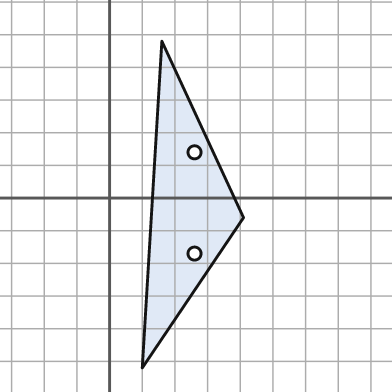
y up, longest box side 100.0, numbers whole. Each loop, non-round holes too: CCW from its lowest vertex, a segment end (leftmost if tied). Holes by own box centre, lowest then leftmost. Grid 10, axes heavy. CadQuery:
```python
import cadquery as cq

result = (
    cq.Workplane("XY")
    .moveTo(10.0, -52.0)
    .lineTo(41.0, -6.0)
    .lineTo(16.0, 48.0)
    .close()
    .moveTo(26.0, -17.0)
    .circle(2.0)
    .moveTo(26.0, 14.0)
    .circle(2.0)
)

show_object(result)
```